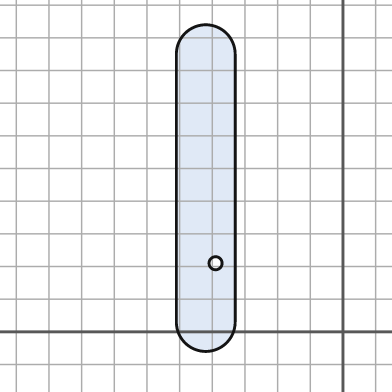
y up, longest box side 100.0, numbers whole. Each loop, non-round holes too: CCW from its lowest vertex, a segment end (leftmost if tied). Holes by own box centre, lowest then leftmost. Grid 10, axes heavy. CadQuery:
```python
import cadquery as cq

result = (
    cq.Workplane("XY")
    .moveTo(-51.0, 3.0)
    .threePointArc((-42.0, -6.0), (-33.0, 3.0))
    .lineTo(-33.0, 85.0)
    .threePointArc((-42.0, 94.0), (-51.0, 85.0))
    .close()
    .moveTo(-39.0, 21.0)
    .circle(2.0)
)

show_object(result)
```